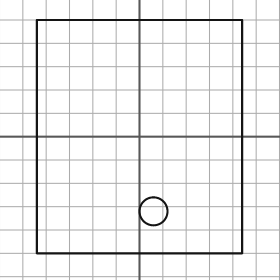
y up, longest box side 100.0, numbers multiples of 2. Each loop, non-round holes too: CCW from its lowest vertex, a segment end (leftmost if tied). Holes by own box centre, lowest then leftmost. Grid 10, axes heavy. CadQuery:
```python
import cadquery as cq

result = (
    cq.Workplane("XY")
    .moveTo(-44.0, -50.0)
    .lineTo(44.0, -50.0)
    .lineTo(44.0, 50.0)
    .lineTo(-44.0, 50.0)
    .close()
    .moveTo(6.0, -32.0)
    .circle(6.0)
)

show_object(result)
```